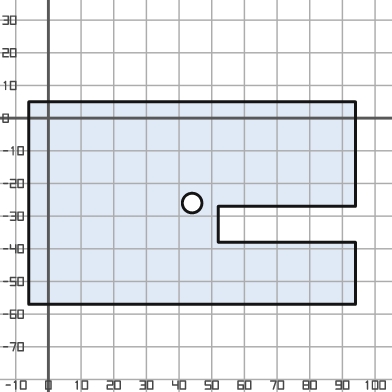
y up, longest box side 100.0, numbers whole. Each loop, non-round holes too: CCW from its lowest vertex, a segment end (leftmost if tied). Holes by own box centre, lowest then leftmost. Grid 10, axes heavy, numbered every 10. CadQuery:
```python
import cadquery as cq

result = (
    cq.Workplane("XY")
    .moveTo(-6.0, -57.0)
    .lineTo(94.0, -57.0)
    .lineTo(94.0, -38.0)
    .lineTo(52.0, -38.0)
    .lineTo(52.0, -27.0)
    .lineTo(94.0, -27.0)
    .lineTo(94.0, 5.0)
    .lineTo(-6.0, 5.0)
    .close()
    .moveTo(44.0, -26.0)
    .circle(3.0)
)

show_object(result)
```